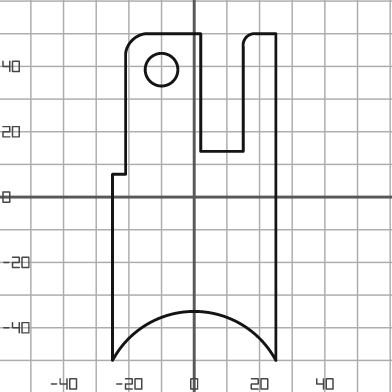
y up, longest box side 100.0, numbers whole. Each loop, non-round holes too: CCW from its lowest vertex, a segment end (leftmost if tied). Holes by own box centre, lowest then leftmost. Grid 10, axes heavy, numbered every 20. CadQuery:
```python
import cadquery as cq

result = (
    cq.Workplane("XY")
    .moveTo(-25.0, -50.0)
    .threePointArc((0.0, -35.0), (25.0, -50.0))
    .lineTo(25.0, 50.0)
    .lineTo(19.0, 50.0)
    .threePointArc((16.0, 49.0), (15.0, 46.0))
    .lineTo(15.0, 14.0)
    .lineTo(2.0, 14.0)
    .lineTo(2.0, 50.0)
    .lineTo(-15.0, 50.0)
    .threePointArc((-19.0, 48.0), (-21.0, 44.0))
    .lineTo(-21.0, 7.0)
    .lineTo(-25.0, 7.0)
    .close()
    .moveTo(-10.0, 39.0)
    .circle(5.0)
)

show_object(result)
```